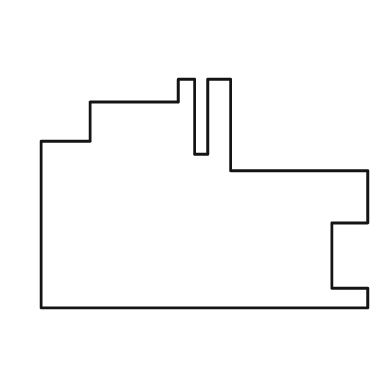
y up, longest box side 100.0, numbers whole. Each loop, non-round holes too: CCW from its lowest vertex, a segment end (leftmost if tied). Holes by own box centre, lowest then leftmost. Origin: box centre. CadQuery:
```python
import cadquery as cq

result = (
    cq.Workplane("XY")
    .moveTo(-50.0, -35.0)
    .lineTo(50.0, -35.0)
    .lineTo(50.0, -29.0)
    .lineTo(39.0, -29.0)
    .lineTo(39.0, -9.0)
    .lineTo(50.0, -9.0)
    .lineTo(50.0, 7.0)
    .lineTo(8.0, 7.0)
    .lineTo(8.0, 35.0)
    .lineTo(1.0, 35.0)
    .lineTo(1.0, 12.0)
    .lineTo(-3.0, 12.0)
    .lineTo(-3.0, 35.0)
    .lineTo(-8.0, 35.0)
    .lineTo(-8.0, 28.0)
    .lineTo(-35.0, 28.0)
    .lineTo(-35.0, 16.0)
    .lineTo(-50.0, 16.0)
    .close()
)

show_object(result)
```